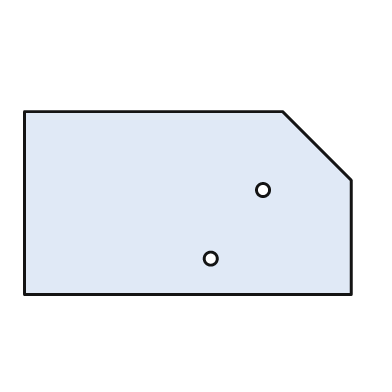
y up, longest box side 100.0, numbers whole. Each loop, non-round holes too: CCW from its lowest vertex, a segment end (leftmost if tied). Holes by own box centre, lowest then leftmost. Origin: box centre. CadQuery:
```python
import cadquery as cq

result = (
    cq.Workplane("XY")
    .moveTo(-50.0, -28.0)
    .lineTo(50.0, -28.0)
    .lineTo(50.0, 7.0)
    .lineTo(29.0, 28.0)
    .lineTo(-50.0, 28.0)
    .close()
    .moveTo(7.0, -17.0)
    .circle(2.0)
    .moveTo(23.0, 4.0)
    .circle(2.0)
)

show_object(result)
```